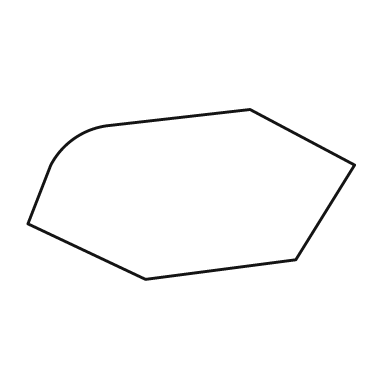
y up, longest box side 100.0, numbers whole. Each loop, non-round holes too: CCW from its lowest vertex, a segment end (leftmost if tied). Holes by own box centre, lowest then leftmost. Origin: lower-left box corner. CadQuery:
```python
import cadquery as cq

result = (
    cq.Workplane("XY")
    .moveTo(36.0, 0.0)
    .lineTo(82.0, 6.0)
    .lineTo(100.0, 35.0)
    .lineTo(68.0, 52.0)
    .lineTo(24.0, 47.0)
    .threePointArc((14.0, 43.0), (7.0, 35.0))
    .lineTo(0.0, 17.0)
    .close()
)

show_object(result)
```